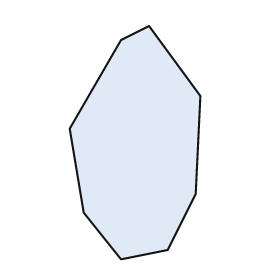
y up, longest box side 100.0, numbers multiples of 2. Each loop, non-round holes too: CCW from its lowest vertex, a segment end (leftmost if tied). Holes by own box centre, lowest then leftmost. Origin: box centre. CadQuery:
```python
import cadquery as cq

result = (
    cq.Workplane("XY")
    .moveTo(-6.0, -50.0)
    .lineTo(14.0, -46.0)
    .lineTo(26.0, -22.0)
    .lineTo(28.0, 20.0)
    .lineTo(6.0, 50.0)
    .lineTo(-6.0, 44.0)
    .lineTo(-28.0, 6.0)
    .lineTo(-22.0, -30.0)
    .close()
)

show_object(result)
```